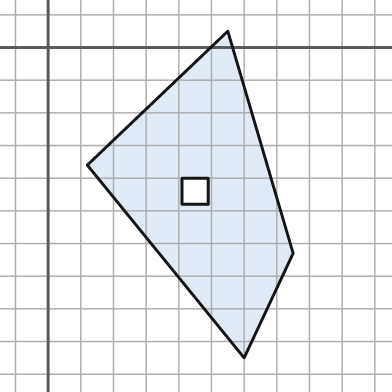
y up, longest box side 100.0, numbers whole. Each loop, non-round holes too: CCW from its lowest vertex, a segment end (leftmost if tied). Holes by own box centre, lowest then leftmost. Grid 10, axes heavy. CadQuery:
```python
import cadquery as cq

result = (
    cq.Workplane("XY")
    .moveTo(60.0, -95.0)
    .lineTo(75.0, -63.0)
    .lineTo(55.0, 5.0)
    .lineTo(12.0, -36.0)
    .close()
    .moveTo(41.0, -48.0)
    .lineTo(49.0, -48.0)
    .lineTo(49.0, -40.0)
    .lineTo(41.0, -40.0)
    .close()
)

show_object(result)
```